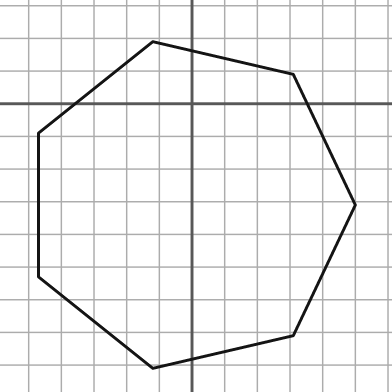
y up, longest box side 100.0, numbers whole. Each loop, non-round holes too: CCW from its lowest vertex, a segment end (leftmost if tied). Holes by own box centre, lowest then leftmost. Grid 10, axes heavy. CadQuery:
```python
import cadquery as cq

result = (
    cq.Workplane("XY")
    .moveTo(-12.0, -81.0)
    .lineTo(31.0, -71.0)
    .lineTo(50.0, -31.0)
    .lineTo(31.0, 9.0)
    .lineTo(-12.0, 19.0)
    .lineTo(-47.0, -9.0)
    .lineTo(-47.0, -53.0)
    .close()
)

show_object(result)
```